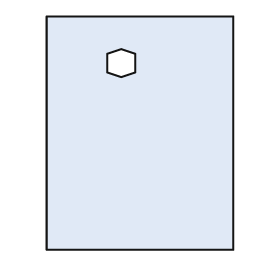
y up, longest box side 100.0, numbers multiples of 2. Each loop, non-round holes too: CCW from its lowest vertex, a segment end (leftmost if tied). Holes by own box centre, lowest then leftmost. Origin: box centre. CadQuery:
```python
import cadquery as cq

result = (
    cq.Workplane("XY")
    .moveTo(-40.0, -50.0)
    .lineTo(40.0, -50.0)
    .lineTo(40.0, 50.0)
    .lineTo(-40.0, 50.0)
    .close()
    .moveTo(-8.0, 24.0)
    .lineTo(-2.0, 26.0)
    .lineTo(-2.0, 34.0)
    .lineTo(-8.0, 36.0)
    .lineTo(-14.0, 34.0)
    .lineTo(-14.0, 26.0)
    .close()
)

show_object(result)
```